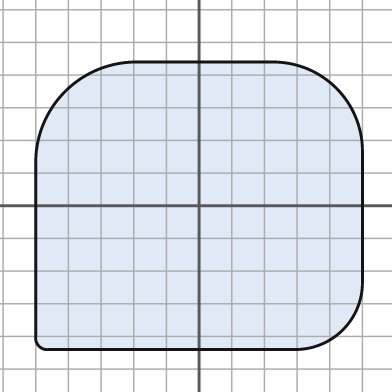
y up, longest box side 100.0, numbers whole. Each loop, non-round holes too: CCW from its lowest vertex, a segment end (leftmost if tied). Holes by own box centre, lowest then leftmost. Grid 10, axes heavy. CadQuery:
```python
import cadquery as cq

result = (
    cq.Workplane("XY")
    .moveTo(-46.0, -44.0)
    .lineTo(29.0, -44.0)
    .threePointArc((44.0, -38.0), (50.0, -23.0))
    .lineTo(50.0, 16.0)
    .threePointArc((42.0, 36.0), (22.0, 44.0))
    .lineTo(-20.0, 44.0)
    .threePointArc((-41.0, 35.0), (-50.0, 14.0))
    .lineTo(-50.0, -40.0)
    .threePointArc((-49.0, -43.0), (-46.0, -44.0))
    .close()
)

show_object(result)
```